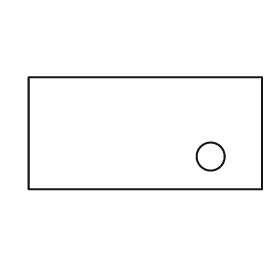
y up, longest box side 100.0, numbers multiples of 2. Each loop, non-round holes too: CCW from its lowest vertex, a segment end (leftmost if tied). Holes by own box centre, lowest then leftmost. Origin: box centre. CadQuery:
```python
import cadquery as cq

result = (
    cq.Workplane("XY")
    .moveTo(-50.0, -24.0)
    .lineTo(50.0, -24.0)
    .lineTo(50.0, 24.0)
    .lineTo(-50.0, 24.0)
    .close()
    .moveTo(28.0, -10.0)
    .circle(6.0)
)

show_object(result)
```